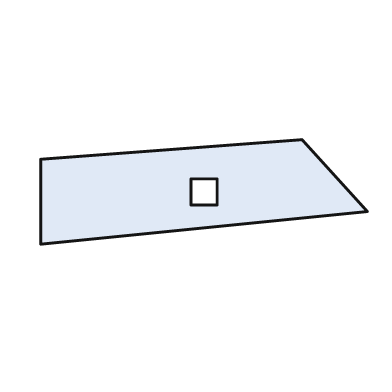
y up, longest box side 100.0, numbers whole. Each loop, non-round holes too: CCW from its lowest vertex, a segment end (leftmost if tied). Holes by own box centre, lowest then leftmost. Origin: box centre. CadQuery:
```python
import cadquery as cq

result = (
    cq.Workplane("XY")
    .moveTo(-50.0, -16.0)
    .lineTo(50.0, -6.0)
    .lineTo(30.0, 16.0)
    .lineTo(-50.0, 10.0)
    .close()
    .moveTo(-4.0, -4.0)
    .lineTo(4.0, -4.0)
    .lineTo(4.0, 4.0)
    .lineTo(-4.0, 4.0)
    .close()
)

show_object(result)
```